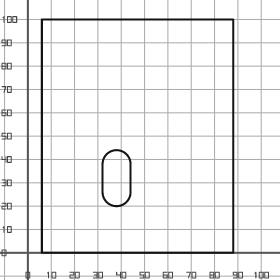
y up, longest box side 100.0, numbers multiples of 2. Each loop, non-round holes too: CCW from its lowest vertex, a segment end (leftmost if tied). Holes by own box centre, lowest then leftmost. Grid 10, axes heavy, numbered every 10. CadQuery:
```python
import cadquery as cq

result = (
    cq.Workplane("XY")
    .moveTo(6.0, 0.0)
    .lineTo(88.0, 0.0)
    .lineTo(88.0, 100.0)
    .lineTo(6.0, 100.0)
    .close()
    .moveTo(32.0, 26.0)
    .threePointArc((38.0, 20.0), (44.0, 26.0))
    .lineTo(44.0, 38.0)
    .threePointArc((38.0, 44.0), (32.0, 38.0))
    .close()
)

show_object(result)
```